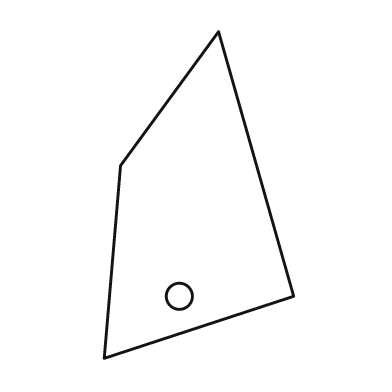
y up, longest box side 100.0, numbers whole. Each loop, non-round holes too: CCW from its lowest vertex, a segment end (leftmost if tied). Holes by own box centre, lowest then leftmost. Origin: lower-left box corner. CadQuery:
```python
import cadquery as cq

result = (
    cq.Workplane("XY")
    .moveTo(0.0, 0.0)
    .lineTo(58.0, 19.0)
    .lineTo(35.0, 100.0)
    .lineTo(5.0, 59.0)
    .close()
    .moveTo(23.0, 19.0)
    .circle(4.0)
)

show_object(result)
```